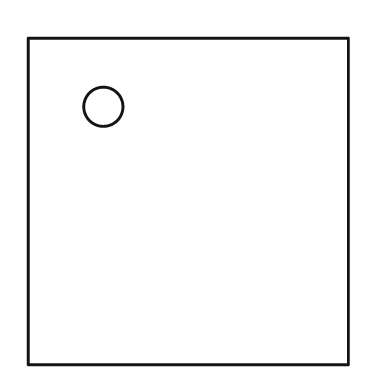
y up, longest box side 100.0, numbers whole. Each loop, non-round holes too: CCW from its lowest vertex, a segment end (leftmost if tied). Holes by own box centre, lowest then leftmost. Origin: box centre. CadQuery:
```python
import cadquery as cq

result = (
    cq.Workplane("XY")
    .moveTo(-49.0, -50.0)
    .lineTo(49.0, -50.0)
    .lineTo(49.0, 50.0)
    .lineTo(-49.0, 50.0)
    .close()
    .moveTo(-26.0, 29.0)
    .circle(6.0)
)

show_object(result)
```